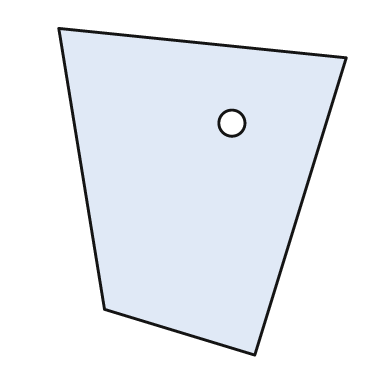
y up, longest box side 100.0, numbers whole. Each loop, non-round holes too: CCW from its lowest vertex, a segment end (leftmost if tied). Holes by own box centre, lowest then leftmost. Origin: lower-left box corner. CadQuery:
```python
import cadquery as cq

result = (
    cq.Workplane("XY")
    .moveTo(60.0, 0.0)
    .lineTo(88.0, 91.0)
    .lineTo(0.0, 100.0)
    .lineTo(14.0, 14.0)
    .close()
    .moveTo(53.0, 71.0)
    .circle(4.0)
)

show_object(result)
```